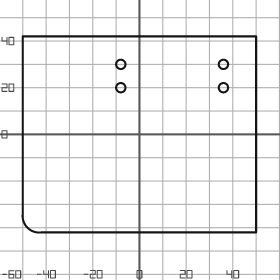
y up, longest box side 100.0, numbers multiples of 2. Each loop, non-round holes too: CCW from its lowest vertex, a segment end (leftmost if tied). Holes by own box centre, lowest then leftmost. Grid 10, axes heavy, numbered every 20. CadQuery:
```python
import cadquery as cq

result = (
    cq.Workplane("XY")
    .moveTo(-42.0, -42.0)
    .lineTo(50.0, -42.0)
    .lineTo(50.0, 42.0)
    .lineTo(-50.0, 42.0)
    .lineTo(-50.0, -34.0)
    .threePointArc((-48.0, -40.0), (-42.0, -42.0))
    .close()
    .moveTo(-8.0, 20.0)
    .circle(2.0)
    .moveTo(36.0, 20.0)
    .circle(2.0)
    .moveTo(-8.0, 30.0)
    .circle(2.0)
    .moveTo(36.0, 30.0)
    .circle(2.0)
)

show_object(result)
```